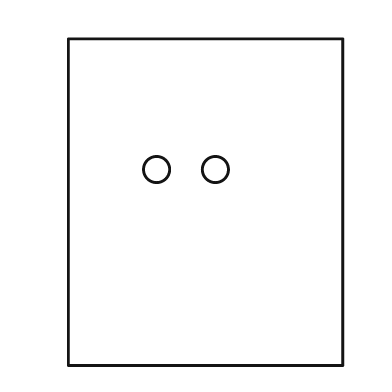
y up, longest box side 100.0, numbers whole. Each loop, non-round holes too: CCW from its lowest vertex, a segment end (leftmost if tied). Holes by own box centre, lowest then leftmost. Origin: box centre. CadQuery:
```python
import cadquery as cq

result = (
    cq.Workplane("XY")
    .moveTo(-42.0, -50.0)
    .lineTo(42.0, -50.0)
    .lineTo(42.0, 50.0)
    .lineTo(-42.0, 50.0)
    .close()
    .moveTo(-15.0, 10.0)
    .circle(4.0)
    .moveTo(3.0, 10.0)
    .circle(4.0)
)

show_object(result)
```